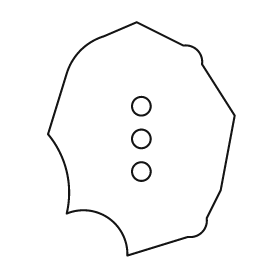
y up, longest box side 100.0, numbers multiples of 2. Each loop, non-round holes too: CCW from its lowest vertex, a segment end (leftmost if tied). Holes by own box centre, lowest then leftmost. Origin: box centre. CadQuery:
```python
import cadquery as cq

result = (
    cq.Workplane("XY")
    .moveTo(-6.0, -50.0)
    .lineTo(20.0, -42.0)
    .threePointArc((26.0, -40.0), (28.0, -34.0))
    .lineTo(34.0, -22.0)
    .lineTo(40.0, 10.0)
    .lineTo(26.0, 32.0)
    .threePointArc((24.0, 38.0), (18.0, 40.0))
    .lineTo(-2.0, 50.0)
    .lineTo(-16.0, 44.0)
    .threePointArc((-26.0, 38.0), (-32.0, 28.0))
    .lineTo(-40.0, 2.0)
    .threePointArc((-32.0, -14.0), (-32.0, -32.0))
    .threePointArc((-14.0, -34.0), (-6.0, -50.0))
    .close()
    .moveTo(0.0, -14.0)
    .circle(4.0)
    .moveTo(0.0, 0.0)
    .circle(4.0)
    .moveTo(0.0, 14.0)
    .circle(4.0)
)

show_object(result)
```